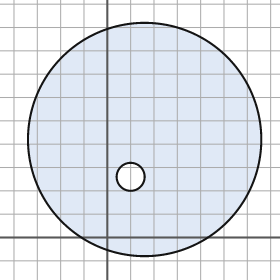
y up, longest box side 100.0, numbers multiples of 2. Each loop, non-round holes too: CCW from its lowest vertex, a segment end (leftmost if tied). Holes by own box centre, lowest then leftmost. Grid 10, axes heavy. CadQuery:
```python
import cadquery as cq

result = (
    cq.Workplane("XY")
    .moveTo(16.0, 42.0)
    .circle(50.0)
    .moveTo(10.0, 26.0)
    .circle(6.0)
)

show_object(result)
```